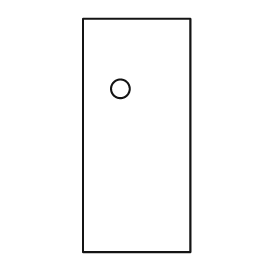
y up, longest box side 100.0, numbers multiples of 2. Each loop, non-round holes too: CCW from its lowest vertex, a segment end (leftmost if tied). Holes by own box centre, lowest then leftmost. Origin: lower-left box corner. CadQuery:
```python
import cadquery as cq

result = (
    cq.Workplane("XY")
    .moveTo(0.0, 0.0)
    .lineTo(46.0, 0.0)
    .lineTo(46.0, 100.0)
    .lineTo(0.0, 100.0)
    .close()
    .moveTo(16.0, 70.0)
    .circle(4.0)
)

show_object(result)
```